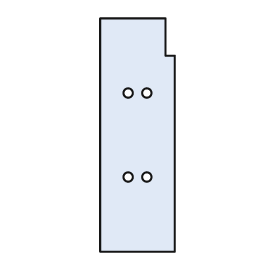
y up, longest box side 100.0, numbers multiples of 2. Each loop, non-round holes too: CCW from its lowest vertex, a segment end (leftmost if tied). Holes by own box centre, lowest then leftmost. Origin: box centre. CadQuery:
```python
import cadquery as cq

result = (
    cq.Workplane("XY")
    .moveTo(-16.0, -50.0)
    .lineTo(16.0, -50.0)
    .lineTo(16.0, 34.0)
    .lineTo(12.0, 34.0)
    .lineTo(12.0, 50.0)
    .lineTo(-16.0, 50.0)
    .close()
    .moveTo(-4.0, -18.0)
    .circle(2.0)
    .moveTo(4.0, -18.0)
    .circle(2.0)
    .moveTo(-4.0, 18.0)
    .circle(2.0)
    .moveTo(4.0, 18.0)
    .circle(2.0)
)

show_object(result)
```